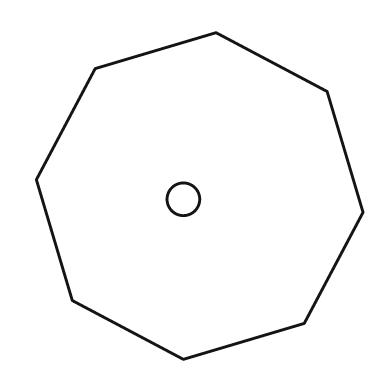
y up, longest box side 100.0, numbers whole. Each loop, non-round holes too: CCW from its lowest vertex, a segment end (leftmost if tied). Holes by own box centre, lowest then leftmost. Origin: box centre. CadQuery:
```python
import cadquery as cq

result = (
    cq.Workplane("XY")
    .moveTo(-5.0, -50.0)
    .lineTo(32.0, -39.0)
    .lineTo(50.0, -5.0)
    .lineTo(39.0, 32.0)
    .lineTo(5.0, 50.0)
    .lineTo(-32.0, 39.0)
    .lineTo(-50.0, 5.0)
    .lineTo(-39.0, -32.0)
    .close()
    .moveTo(-5.0, -1.0)
    .circle(5.0)
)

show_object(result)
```